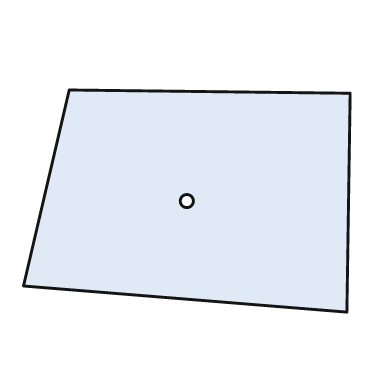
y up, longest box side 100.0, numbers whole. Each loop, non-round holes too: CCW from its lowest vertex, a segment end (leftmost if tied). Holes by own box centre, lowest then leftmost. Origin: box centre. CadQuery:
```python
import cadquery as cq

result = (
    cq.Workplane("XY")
    .moveTo(49.0, -34.0)
    .lineTo(50.0, 33.0)
    .lineTo(-36.0, 34.0)
    .lineTo(-50.0, -26.0)
    .close()
    .moveTo(0.0, 0.0)
    .circle(2.0)
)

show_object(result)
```